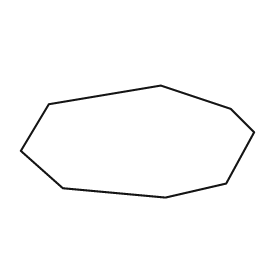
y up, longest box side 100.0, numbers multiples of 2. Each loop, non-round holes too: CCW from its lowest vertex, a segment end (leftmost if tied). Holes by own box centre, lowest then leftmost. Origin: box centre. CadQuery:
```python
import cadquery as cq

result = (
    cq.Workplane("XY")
    .moveTo(12.0, -24.0)
    .lineTo(38.0, -18.0)
    .lineTo(50.0, 4.0)
    .lineTo(40.0, 14.0)
    .lineTo(10.0, 24.0)
    .lineTo(-38.0, 16.0)
    .lineTo(-50.0, -4.0)
    .lineTo(-32.0, -20.0)
    .close()
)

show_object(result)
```